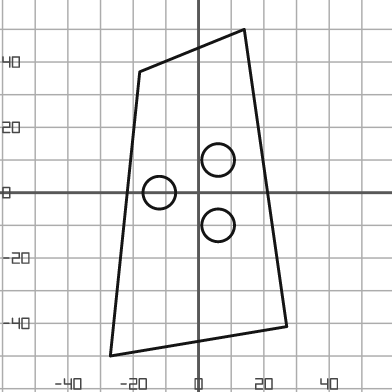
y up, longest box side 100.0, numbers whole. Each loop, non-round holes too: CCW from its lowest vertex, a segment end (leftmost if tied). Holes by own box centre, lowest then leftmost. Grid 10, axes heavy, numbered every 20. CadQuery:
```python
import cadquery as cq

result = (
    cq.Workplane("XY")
    .moveTo(-27.0, -50.0)
    .lineTo(27.0, -41.0)
    .lineTo(14.0, 50.0)
    .lineTo(-18.0, 37.0)
    .close()
    .moveTo(6.0, -10.0)
    .circle(5.0)
    .moveTo(-12.0, 0.0)
    .circle(5.0)
    .moveTo(6.0, 10.0)
    .circle(5.0)
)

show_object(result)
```